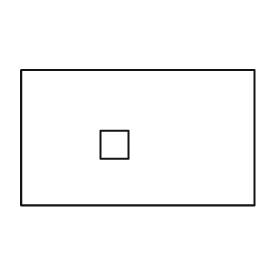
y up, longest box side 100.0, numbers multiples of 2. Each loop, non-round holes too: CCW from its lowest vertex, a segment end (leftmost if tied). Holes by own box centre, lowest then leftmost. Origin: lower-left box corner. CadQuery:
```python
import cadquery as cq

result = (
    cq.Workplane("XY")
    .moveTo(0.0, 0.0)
    .lineTo(100.0, 0.0)
    .lineTo(100.0, 58.0)
    .lineTo(0.0, 58.0)
    .close()
    .moveTo(34.0, 20.0)
    .lineTo(46.0, 20.0)
    .lineTo(46.0, 32.0)
    .lineTo(34.0, 32.0)
    .close()
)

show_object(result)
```